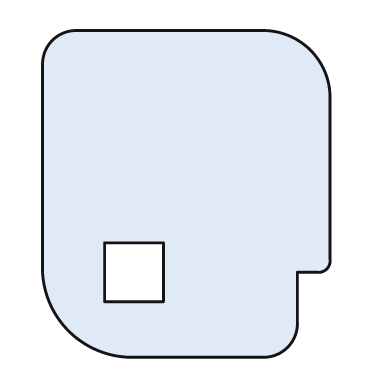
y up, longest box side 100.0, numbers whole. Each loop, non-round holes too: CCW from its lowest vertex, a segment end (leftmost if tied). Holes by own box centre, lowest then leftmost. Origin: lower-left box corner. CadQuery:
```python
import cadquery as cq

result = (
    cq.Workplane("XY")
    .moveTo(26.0, 0.0)
    .lineTo(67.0, 0.0)
    .threePointArc((75.0, 3.0), (78.0, 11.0))
    .lineTo(78.0, 26.0)
    .lineTo(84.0, 26.0)
    .threePointArc((87.0, 27.0), (88.0, 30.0))
    .lineTo(88.0, 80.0)
    .threePointArc((82.0, 94.0), (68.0, 100.0))
    .lineTo(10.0, 100.0)
    .threePointArc((3.0, 97.0), (0.0, 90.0))
    .lineTo(0.0, 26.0)
    .threePointArc((8.0, 8.0), (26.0, 0.0))
    .close()
    .moveTo(19.0, 17.0)
    .lineTo(37.0, 17.0)
    .lineTo(37.0, 35.0)
    .lineTo(19.0, 35.0)
    .close()
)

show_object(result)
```